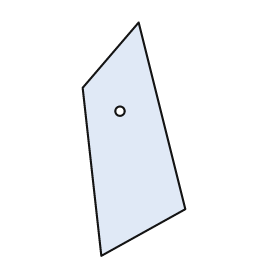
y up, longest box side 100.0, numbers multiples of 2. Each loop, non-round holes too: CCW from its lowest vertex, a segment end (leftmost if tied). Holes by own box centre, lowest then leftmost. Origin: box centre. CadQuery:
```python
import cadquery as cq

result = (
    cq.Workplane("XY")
    .moveTo(-14.0, -50.0)
    .lineTo(22.0, -30.0)
    .lineTo(2.0, 50.0)
    .lineTo(-22.0, 22.0)
    .close()
    .moveTo(-6.0, 12.0)
    .circle(2.0)
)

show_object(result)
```